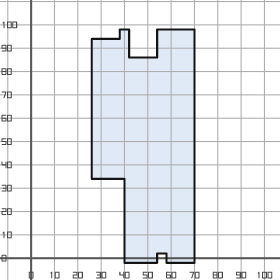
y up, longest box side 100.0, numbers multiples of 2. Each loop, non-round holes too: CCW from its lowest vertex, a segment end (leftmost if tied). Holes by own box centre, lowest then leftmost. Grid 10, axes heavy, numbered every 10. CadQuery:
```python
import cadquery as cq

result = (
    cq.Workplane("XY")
    .moveTo(40.0, -2.0)
    .lineTo(54.0, -2.0)
    .lineTo(54.0, 2.0)
    .lineTo(58.0, 2.0)
    .lineTo(58.0, -2.0)
    .lineTo(70.0, -2.0)
    .lineTo(70.0, 98.0)
    .lineTo(54.0, 98.0)
    .lineTo(54.0, 86.0)
    .lineTo(42.0, 86.0)
    .lineTo(42.0, 98.0)
    .lineTo(38.0, 98.0)
    .lineTo(38.0, 94.0)
    .lineTo(26.0, 94.0)
    .lineTo(26.0, 34.0)
    .lineTo(40.0, 34.0)
    .close()
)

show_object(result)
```